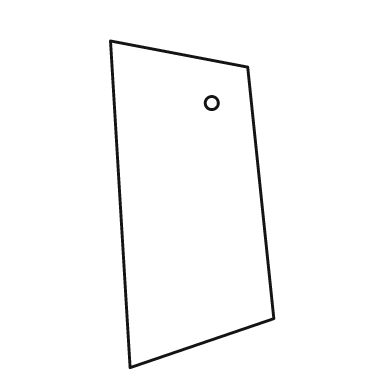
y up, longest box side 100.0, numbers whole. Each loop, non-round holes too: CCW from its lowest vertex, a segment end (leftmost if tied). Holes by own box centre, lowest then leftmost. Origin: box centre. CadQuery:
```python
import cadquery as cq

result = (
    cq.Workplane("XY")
    .moveTo(-19.0, -50.0)
    .lineTo(25.0, -35.0)
    .lineTo(17.0, 42.0)
    .lineTo(-25.0, 50.0)
    .close()
    .moveTo(6.0, 31.0)
    .circle(2.0)
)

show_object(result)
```